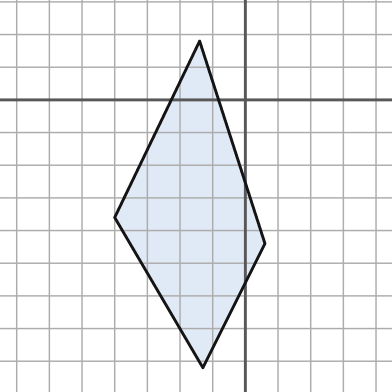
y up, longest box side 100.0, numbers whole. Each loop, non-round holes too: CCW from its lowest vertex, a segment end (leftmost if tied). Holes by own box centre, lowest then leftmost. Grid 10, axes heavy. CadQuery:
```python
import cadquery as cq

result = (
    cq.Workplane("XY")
    .moveTo(-13.0, -82.0)
    .lineTo(6.0, -44.0)
    .lineTo(-14.0, 18.0)
    .lineTo(-40.0, -36.0)
    .close()
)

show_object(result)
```